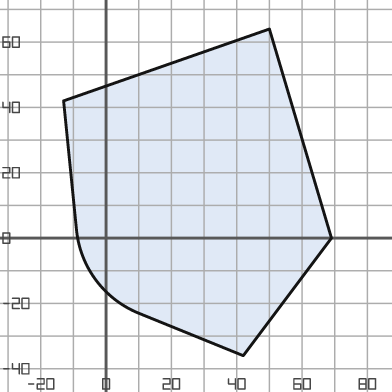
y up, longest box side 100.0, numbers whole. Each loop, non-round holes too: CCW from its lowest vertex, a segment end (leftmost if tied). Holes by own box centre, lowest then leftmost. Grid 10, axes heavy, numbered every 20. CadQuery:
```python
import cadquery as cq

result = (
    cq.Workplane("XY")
    .moveTo(42.0, -36.0)
    .lineTo(69.0, 0.0)
    .lineTo(50.0, 64.0)
    .lineTo(-13.0, 42.0)
    .lineTo(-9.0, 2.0)
    .threePointArc((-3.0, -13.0), (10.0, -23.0))
    .close()
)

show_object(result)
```